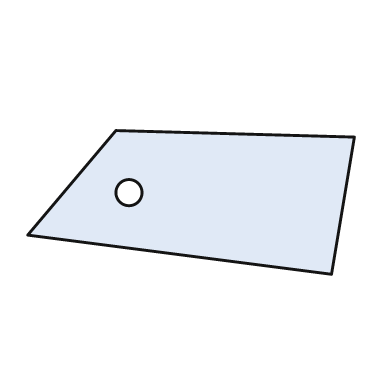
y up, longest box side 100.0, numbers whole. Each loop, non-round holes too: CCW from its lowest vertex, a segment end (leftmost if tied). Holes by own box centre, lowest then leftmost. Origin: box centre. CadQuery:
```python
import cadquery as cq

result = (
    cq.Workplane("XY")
    .moveTo(43.0, -22.0)
    .lineTo(50.0, 20.0)
    .lineTo(-23.0, 22.0)
    .lineTo(-50.0, -10.0)
    .close()
    .moveTo(-19.0, 3.0)
    .circle(4.0)
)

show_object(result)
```